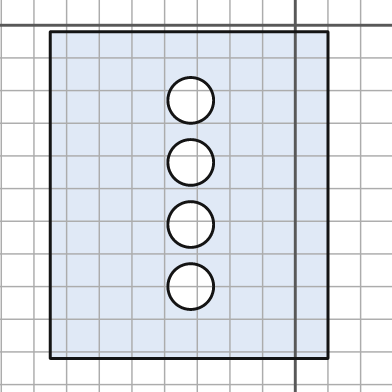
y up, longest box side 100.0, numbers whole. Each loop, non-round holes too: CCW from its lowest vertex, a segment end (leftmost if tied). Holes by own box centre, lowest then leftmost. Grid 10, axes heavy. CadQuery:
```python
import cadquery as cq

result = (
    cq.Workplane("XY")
    .moveTo(-75.0, -102.0)
    .lineTo(10.0, -102.0)
    .lineTo(10.0, -2.0)
    .lineTo(-75.0, -2.0)
    .close()
    .moveTo(-32.0, -80.0)
    .circle(7.0)
    .moveTo(-32.0, -61.0)
    .circle(7.0)
    .moveTo(-32.0, -42.0)
    .circle(7.0)
    .moveTo(-32.0, -23.0)
    .circle(7.0)
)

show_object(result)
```